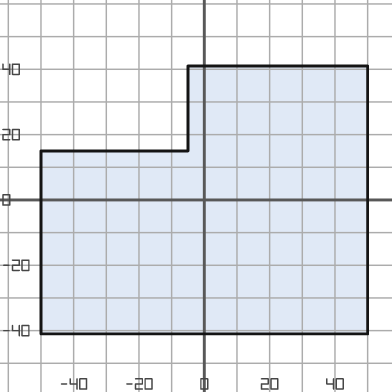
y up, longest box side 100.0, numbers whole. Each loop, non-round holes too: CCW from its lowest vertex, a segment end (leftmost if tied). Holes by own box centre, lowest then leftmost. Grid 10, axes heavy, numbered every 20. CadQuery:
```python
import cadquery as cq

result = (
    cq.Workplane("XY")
    .moveTo(-50.0, -41.0)
    .lineTo(50.0, -41.0)
    .lineTo(50.0, 41.0)
    .lineTo(-5.0, 41.0)
    .lineTo(-5.0, 15.0)
    .lineTo(-50.0, 15.0)
    .close()
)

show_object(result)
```